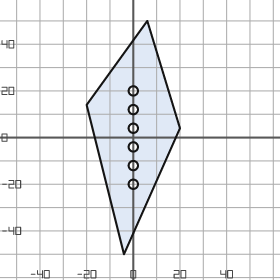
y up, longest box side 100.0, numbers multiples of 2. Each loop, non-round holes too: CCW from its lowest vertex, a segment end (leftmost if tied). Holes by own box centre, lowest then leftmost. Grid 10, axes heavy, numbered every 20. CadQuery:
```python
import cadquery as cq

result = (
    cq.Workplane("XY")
    .moveTo(-4.0, -50.0)
    .lineTo(20.0, 4.0)
    .lineTo(6.0, 50.0)
    .lineTo(-20.0, 14.0)
    .close()
    .moveTo(0.0, -20.0)
    .circle(2.0)
    .moveTo(0.0, -12.0)
    .circle(2.0)
    .moveTo(0.0, -4.0)
    .circle(2.0)
    .moveTo(0.0, 4.0)
    .circle(2.0)
    .moveTo(0.0, 12.0)
    .circle(2.0)
    .moveTo(0.0, 20.0)
    .circle(2.0)
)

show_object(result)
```